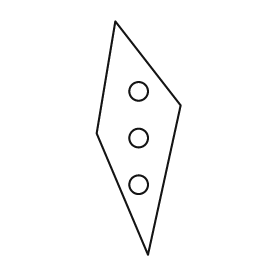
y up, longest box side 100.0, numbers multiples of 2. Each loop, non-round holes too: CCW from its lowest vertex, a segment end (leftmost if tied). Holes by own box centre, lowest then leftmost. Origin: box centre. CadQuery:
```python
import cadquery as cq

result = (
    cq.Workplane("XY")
    .moveTo(4.0, -50.0)
    .lineTo(18.0, 14.0)
    .lineTo(-10.0, 50.0)
    .lineTo(-18.0, 2.0)
    .close()
    .moveTo(0.0, -20.0)
    .circle(4.0)
    .moveTo(0.0, 0.0)
    .circle(4.0)
    .moveTo(0.0, 20.0)
    .circle(4.0)
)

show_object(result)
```